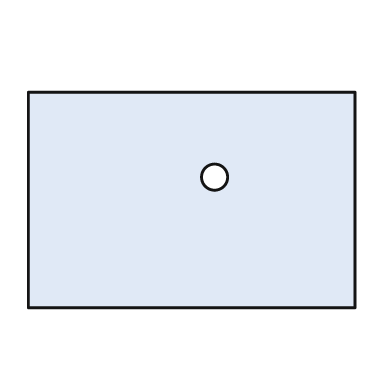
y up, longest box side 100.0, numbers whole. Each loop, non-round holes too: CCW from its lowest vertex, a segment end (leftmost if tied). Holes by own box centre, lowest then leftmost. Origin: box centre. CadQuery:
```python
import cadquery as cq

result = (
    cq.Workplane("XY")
    .moveTo(-50.0, -33.0)
    .lineTo(50.0, -33.0)
    .lineTo(50.0, 33.0)
    .lineTo(-50.0, 33.0)
    .close()
    .moveTo(7.0, 7.0)
    .circle(4.0)
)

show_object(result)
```